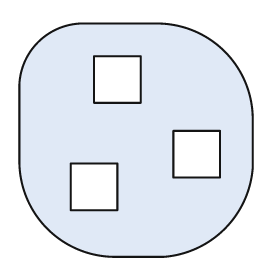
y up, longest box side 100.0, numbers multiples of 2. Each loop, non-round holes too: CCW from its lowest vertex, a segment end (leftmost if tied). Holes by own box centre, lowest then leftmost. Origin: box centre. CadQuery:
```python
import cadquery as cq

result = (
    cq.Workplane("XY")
    .moveTo(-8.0, -50.0)
    .lineTo(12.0, -50.0)
    .threePointArc((38.0, -38.0), (50.0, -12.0))
    .lineTo(50.0, 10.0)
    .threePointArc((38.0, 38.0), (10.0, 50.0))
    .lineTo(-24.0, 50.0)
    .threePointArc((-42.0, 42.0), (-50.0, 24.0))
    .lineTo(-50.0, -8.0)
    .threePointArc((-38.0, -38.0), (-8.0, -50.0))
    .close()
    .moveTo(-28.0, -30.0)
    .lineTo(-8.0, -30.0)
    .lineTo(-8.0, -10.0)
    .lineTo(-28.0, -10.0)
    .close()
    .moveTo(16.0, -16.0)
    .lineTo(36.0, -16.0)
    .lineTo(36.0, 4.0)
    .lineTo(16.0, 4.0)
    .close()
    .moveTo(-18.0, 16.0)
    .lineTo(2.0, 16.0)
    .lineTo(2.0, 36.0)
    .lineTo(-18.0, 36.0)
    .close()
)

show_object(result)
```